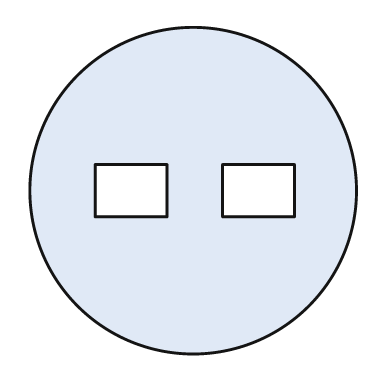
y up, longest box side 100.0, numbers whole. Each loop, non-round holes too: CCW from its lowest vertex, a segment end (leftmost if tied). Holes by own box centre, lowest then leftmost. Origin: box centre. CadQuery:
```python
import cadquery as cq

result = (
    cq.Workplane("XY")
    .moveTo(0.0, 0.0)
    .circle(50.0)
    .moveTo(-30.0, -8.0)
    .lineTo(-8.0, -8.0)
    .lineTo(-8.0, 8.0)
    .lineTo(-30.0, 8.0)
    .close()
    .moveTo(9.0, -8.0)
    .lineTo(31.0, -8.0)
    .lineTo(31.0, 8.0)
    .lineTo(9.0, 8.0)
    .close()
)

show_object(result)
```